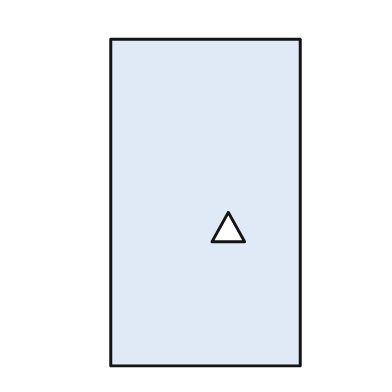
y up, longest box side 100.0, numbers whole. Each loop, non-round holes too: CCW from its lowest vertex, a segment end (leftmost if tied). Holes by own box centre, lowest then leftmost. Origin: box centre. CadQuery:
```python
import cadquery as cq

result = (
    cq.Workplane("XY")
    .moveTo(-29.0, -50.0)
    .lineTo(29.0, -50.0)
    .lineTo(29.0, 50.0)
    .lineTo(-29.0, 50.0)
    .close()
    .moveTo(2.0, -12.0)
    .lineTo(12.0, -12.0)
    .lineTo(7.0, -3.0)
    .close()
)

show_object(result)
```